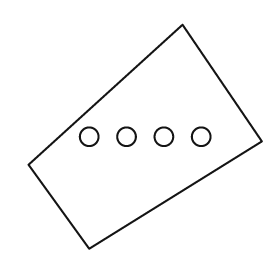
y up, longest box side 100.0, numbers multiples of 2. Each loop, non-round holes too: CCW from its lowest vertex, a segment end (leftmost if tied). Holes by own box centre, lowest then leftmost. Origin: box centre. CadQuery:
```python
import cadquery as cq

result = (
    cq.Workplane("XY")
    .moveTo(-24.0, -48.0)
    .lineTo(50.0, -2.0)
    .lineTo(16.0, 48.0)
    .lineTo(-50.0, -12.0)
    .close()
    .moveTo(-24.0, 0.0)
    .circle(4.0)
    .moveTo(-8.0, 0.0)
    .circle(4.0)
    .moveTo(8.0, 0.0)
    .circle(4.0)
    .moveTo(24.0, 0.0)
    .circle(4.0)
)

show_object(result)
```